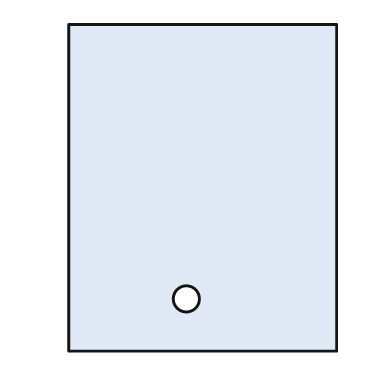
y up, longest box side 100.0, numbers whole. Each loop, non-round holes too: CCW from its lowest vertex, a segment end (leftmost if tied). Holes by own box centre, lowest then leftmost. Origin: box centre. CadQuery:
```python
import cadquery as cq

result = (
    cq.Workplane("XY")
    .moveTo(-41.0, -50.0)
    .lineTo(41.0, -50.0)
    .lineTo(41.0, 50.0)
    .lineTo(-41.0, 50.0)
    .close()
    .moveTo(-5.0, -34.0)
    .circle(4.0)
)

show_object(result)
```